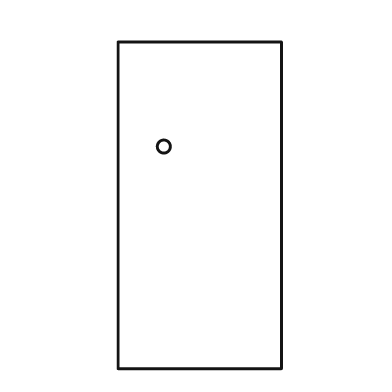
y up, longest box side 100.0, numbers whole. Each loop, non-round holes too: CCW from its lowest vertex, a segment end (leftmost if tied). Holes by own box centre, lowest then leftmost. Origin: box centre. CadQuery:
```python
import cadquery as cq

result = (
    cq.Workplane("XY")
    .moveTo(-25.0, -50.0)
    .lineTo(25.0, -50.0)
    .lineTo(25.0, 50.0)
    .lineTo(-25.0, 50.0)
    .close()
    .moveTo(-11.0, 18.0)
    .circle(2.0)
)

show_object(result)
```